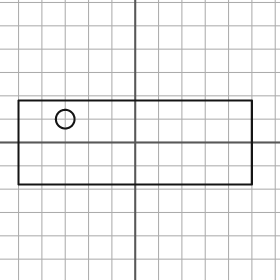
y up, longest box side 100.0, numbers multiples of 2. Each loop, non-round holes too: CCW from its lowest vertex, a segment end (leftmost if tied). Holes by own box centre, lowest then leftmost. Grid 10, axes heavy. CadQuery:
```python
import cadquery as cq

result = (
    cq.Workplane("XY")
    .moveTo(-50.0, -18.0)
    .lineTo(50.0, -18.0)
    .lineTo(50.0, 18.0)
    .lineTo(-50.0, 18.0)
    .close()
    .moveTo(-30.0, 10.0)
    .circle(4.0)
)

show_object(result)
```